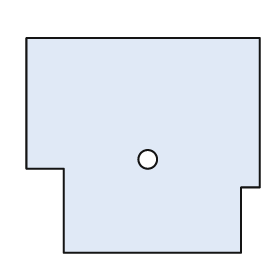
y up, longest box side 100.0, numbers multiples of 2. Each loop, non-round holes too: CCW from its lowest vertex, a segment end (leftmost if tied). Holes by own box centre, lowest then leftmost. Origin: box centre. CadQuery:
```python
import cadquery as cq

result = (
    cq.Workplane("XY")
    .moveTo(-34.0, -46.0)
    .lineTo(42.0, -46.0)
    .lineTo(42.0, -18.0)
    .lineTo(50.0, -18.0)
    .lineTo(50.0, 46.0)
    .lineTo(-50.0, 46.0)
    .lineTo(-50.0, -10.0)
    .lineTo(-34.0, -10.0)
    .close()
    .moveTo(2.0, -6.0)
    .circle(4.0)
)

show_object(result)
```